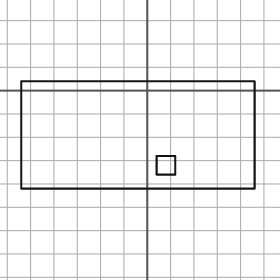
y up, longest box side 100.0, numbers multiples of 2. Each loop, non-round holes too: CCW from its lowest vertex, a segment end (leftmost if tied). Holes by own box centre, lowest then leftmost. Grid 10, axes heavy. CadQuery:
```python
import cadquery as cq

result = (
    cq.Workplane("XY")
    .moveTo(-54.0, -42.0)
    .lineTo(46.0, -42.0)
    .lineTo(46.0, 4.0)
    .lineTo(-54.0, 4.0)
    .close()
    .moveTo(4.0, -36.0)
    .lineTo(12.0, -36.0)
    .lineTo(12.0, -28.0)
    .lineTo(4.0, -28.0)
    .close()
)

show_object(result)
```